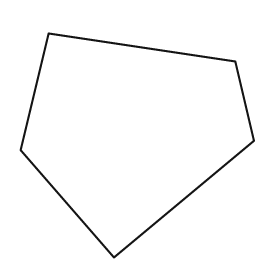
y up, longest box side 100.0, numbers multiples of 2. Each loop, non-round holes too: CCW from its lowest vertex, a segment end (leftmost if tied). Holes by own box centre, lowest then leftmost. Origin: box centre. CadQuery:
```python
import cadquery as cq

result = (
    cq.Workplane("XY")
    .moveTo(-10.0, -48.0)
    .lineTo(50.0, 2.0)
    .lineTo(42.0, 36.0)
    .lineTo(-38.0, 48.0)
    .lineTo(-50.0, -2.0)
    .close()
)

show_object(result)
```